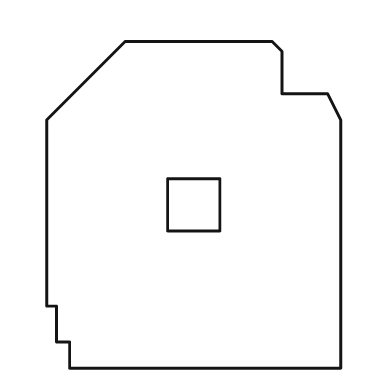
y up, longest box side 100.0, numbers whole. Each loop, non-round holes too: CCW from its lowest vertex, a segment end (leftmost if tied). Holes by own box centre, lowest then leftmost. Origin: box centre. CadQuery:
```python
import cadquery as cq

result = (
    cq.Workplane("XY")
    .moveTo(-38.0, -50.0)
    .lineTo(45.0, -50.0)
    .lineTo(45.0, 26.0)
    .lineTo(41.0, 34.0)
    .lineTo(27.0, 34.0)
    .lineTo(27.0, 47.0)
    .lineTo(24.0, 50.0)
    .lineTo(-21.0, 50.0)
    .lineTo(-45.0, 26.0)
    .lineTo(-45.0, -31.0)
    .lineTo(-42.0, -31.0)
    .lineTo(-42.0, -42.0)
    .lineTo(-38.0, -42.0)
    .close()
    .moveTo(-8.0, -8.0)
    .lineTo(8.0, -8.0)
    .lineTo(8.0, 8.0)
    .lineTo(-8.0, 8.0)
    .close()
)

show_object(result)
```